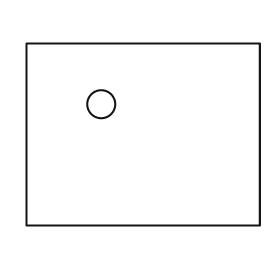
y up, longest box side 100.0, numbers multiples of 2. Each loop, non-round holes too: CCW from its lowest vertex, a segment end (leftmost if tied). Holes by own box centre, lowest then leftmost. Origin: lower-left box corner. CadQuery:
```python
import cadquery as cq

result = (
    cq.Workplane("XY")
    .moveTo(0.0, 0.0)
    .lineTo(100.0, 0.0)
    .lineTo(100.0, 78.0)
    .lineTo(0.0, 78.0)
    .close()
    .moveTo(32.0, 52.0)
    .circle(6.0)
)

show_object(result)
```